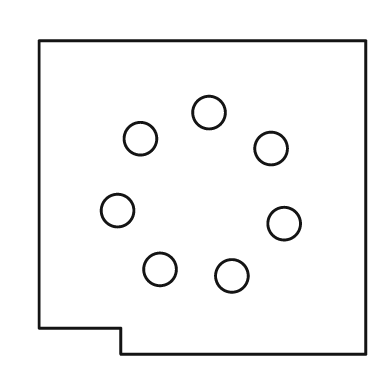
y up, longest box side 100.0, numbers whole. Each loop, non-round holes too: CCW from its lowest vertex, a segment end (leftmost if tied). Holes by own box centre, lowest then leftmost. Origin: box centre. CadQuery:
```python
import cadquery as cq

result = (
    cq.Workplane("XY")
    .moveTo(-25.0, -48.0)
    .lineTo(50.0, -48.0)
    .lineTo(50.0, 48.0)
    .lineTo(-50.0, 48.0)
    .lineTo(-50.0, -40.0)
    .lineTo(-25.0, -40.0)
    .close()
    .moveTo(9.0, -24.0)
    .circle(5.0)
    .moveTo(-13.0, -22.0)
    .circle(5.0)
    .moveTo(25.0, -8.0)
    .circle(5.0)
    .moveTo(-26.0, -4.0)
    .circle(5.0)
    .moveTo(21.0, 15.0)
    .circle(5.0)
    .moveTo(-19.0, 18.0)
    .circle(5.0)
    .moveTo(2.0, 26.0)
    .circle(5.0)
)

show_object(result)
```